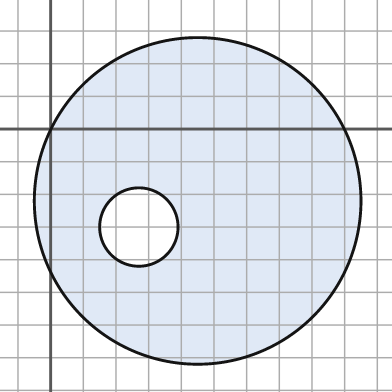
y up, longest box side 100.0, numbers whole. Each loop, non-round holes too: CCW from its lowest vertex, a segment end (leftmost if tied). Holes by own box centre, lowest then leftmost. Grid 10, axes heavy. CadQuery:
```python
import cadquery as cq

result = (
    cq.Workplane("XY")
    .moveTo(45.0, -22.0)
    .circle(50.0)
    .moveTo(27.0, -30.0)
    .circle(12.0)
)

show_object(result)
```